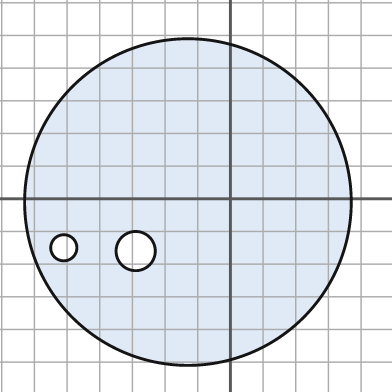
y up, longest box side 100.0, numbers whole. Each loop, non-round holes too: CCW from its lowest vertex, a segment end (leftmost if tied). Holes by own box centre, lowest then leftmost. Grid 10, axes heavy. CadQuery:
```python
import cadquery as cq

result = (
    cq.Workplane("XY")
    .moveTo(-13.0, -1.0)
    .circle(50.0)
    .moveTo(-29.0, -16.0)
    .circle(6.0)
    .moveTo(-51.0, -15.0)
    .circle(4.0)
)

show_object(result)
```